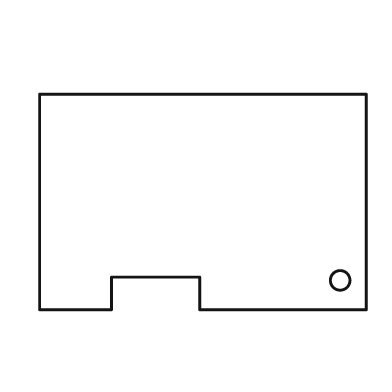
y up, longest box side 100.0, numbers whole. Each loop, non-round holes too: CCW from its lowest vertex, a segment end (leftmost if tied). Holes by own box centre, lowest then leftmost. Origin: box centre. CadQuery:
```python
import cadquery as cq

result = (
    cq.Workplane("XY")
    .moveTo(-50.0, -33.0)
    .lineTo(-28.0, -33.0)
    .lineTo(-28.0, -23.0)
    .lineTo(-1.0, -23.0)
    .lineTo(-1.0, -33.0)
    .lineTo(50.0, -33.0)
    .lineTo(50.0, 33.0)
    .lineTo(-50.0, 33.0)
    .close()
    .moveTo(42.0, -24.0)
    .circle(3.0)
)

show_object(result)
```